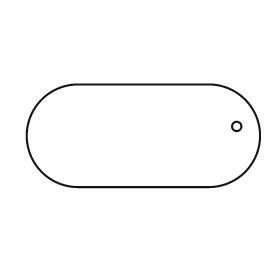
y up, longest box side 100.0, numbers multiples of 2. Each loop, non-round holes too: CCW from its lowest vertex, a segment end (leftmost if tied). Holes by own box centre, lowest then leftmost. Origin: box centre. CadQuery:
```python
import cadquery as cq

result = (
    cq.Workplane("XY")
    .moveTo(-28.0, -22.0)
    .lineTo(28.0, -22.0)
    .threePointArc((50.0, 0.0), (28.0, 22.0))
    .lineTo(-28.0, 22.0)
    .threePointArc((-50.0, 0.0), (-28.0, -22.0))
    .close()
    .moveTo(40.0, 4.0)
    .circle(2.0)
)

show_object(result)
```